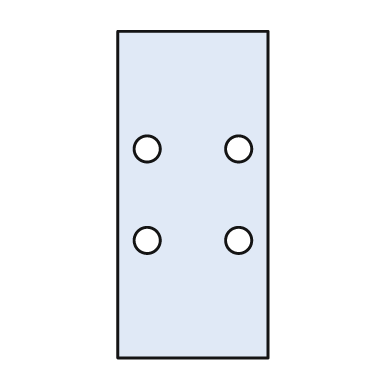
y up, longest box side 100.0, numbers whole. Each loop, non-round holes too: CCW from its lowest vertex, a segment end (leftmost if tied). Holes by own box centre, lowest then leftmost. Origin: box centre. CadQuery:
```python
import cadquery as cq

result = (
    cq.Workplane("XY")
    .moveTo(-23.0, -50.0)
    .lineTo(23.0, -50.0)
    .lineTo(23.0, 50.0)
    .lineTo(-23.0, 50.0)
    .close()
    .moveTo(-14.0, -14.0)
    .circle(4.0)
    .moveTo(14.0, -14.0)
    .circle(4.0)
    .moveTo(-14.0, 14.0)
    .circle(4.0)
    .moveTo(14.0, 14.0)
    .circle(4.0)
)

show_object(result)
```